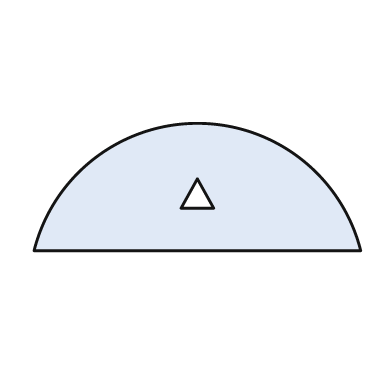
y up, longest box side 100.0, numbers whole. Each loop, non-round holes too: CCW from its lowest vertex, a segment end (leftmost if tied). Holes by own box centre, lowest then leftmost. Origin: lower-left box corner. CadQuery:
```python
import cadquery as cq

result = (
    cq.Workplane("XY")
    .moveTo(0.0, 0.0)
    .lineTo(100.0, 0.0)
    .threePointArc((50.0, 39.0), (0.0, 0.0))
    .close()
    .moveTo(45.0, 13.0)
    .lineTo(55.0, 13.0)
    .lineTo(50.0, 22.0)
    .close()
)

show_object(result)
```